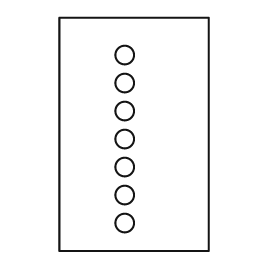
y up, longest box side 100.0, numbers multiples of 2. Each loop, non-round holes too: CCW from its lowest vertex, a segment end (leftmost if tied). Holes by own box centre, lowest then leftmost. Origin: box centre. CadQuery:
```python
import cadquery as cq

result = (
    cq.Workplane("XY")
    .moveTo(-32.0, -50.0)
    .lineTo(32.0, -50.0)
    .lineTo(32.0, 50.0)
    .lineTo(-32.0, 50.0)
    .close()
    .moveTo(-4.0, -38.0)
    .circle(4.0)
    .moveTo(-4.0, -26.0)
    .circle(4.0)
    .moveTo(-4.0, -14.0)
    .circle(4.0)
    .moveTo(-4.0, -2.0)
    .circle(4.0)
    .moveTo(-4.0, 10.0)
    .circle(4.0)
    .moveTo(-4.0, 22.0)
    .circle(4.0)
    .moveTo(-4.0, 34.0)
    .circle(4.0)
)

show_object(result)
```